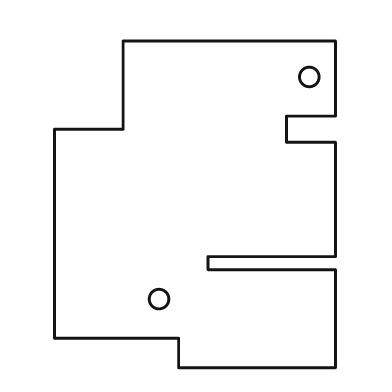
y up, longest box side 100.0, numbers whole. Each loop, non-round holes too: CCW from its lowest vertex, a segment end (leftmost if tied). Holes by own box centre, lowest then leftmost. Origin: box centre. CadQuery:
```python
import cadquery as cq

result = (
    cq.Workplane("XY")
    .moveTo(-5.0, -50.0)
    .lineTo(43.0, -50.0)
    .lineTo(43.0, -20.0)
    .lineTo(4.0, -20.0)
    .lineTo(4.0, -16.0)
    .lineTo(43.0, -16.0)
    .lineTo(43.0, 19.0)
    .lineTo(28.0, 19.0)
    .lineTo(28.0, 27.0)
    .lineTo(43.0, 27.0)
    .lineTo(43.0, 50.0)
    .lineTo(-22.0, 50.0)
    .lineTo(-22.0, 23.0)
    .lineTo(-43.0, 23.0)
    .lineTo(-43.0, -41.0)
    .lineTo(-5.0, -41.0)
    .close()
    .moveTo(-11.0, -29.0)
    .circle(3.0)
    .moveTo(35.0, 39.0)
    .circle(3.0)
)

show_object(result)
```